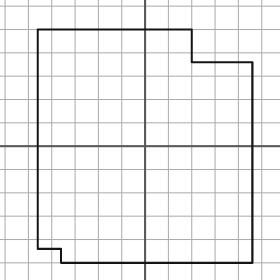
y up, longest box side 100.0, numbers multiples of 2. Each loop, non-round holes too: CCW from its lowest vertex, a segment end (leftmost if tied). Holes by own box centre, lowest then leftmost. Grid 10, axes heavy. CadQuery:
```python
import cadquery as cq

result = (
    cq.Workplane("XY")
    .moveTo(-36.0, -50.0)
    .lineTo(46.0, -50.0)
    .lineTo(46.0, 36.0)
    .lineTo(20.0, 36.0)
    .lineTo(20.0, 50.0)
    .lineTo(-46.0, 50.0)
    .lineTo(-46.0, -44.0)
    .lineTo(-36.0, -44.0)
    .close()
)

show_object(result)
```